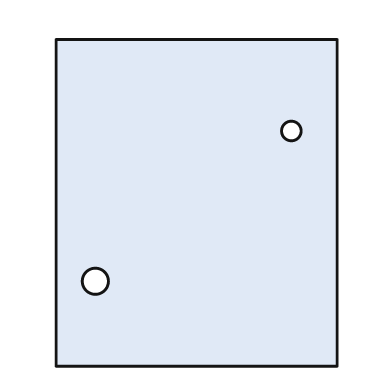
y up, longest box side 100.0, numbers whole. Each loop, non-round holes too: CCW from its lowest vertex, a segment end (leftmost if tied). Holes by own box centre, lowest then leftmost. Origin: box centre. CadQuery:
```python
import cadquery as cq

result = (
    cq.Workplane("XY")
    .moveTo(-43.0, -50.0)
    .lineTo(43.0, -50.0)
    .lineTo(43.0, 50.0)
    .lineTo(-43.0, 50.0)
    .close()
    .moveTo(-31.0, -24.0)
    .circle(4.0)
    .moveTo(29.0, 22.0)
    .circle(3.0)
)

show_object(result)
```